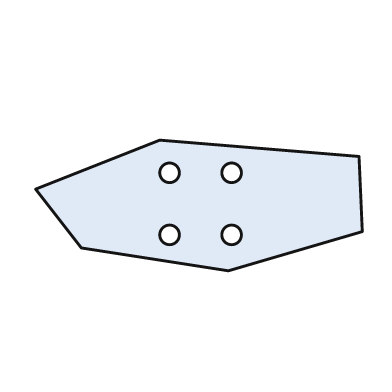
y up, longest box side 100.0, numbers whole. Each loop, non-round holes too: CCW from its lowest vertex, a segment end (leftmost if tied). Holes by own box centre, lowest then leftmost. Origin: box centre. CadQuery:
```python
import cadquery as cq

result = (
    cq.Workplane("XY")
    .moveTo(9.0, -20.0)
    .lineTo(50.0, -8.0)
    .lineTo(49.0, 15.0)
    .lineTo(-12.0, 20.0)
    .lineTo(-50.0, 5.0)
    .lineTo(-36.0, -13.0)
    .close()
    .moveTo(-9.0, -9.0)
    .circle(3.0)
    .moveTo(10.0, -9.0)
    .circle(3.0)
    .moveTo(-9.0, 10.0)
    .circle(3.0)
    .moveTo(10.0, 10.0)
    .circle(3.0)
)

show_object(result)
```